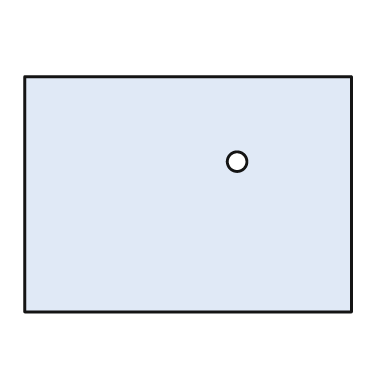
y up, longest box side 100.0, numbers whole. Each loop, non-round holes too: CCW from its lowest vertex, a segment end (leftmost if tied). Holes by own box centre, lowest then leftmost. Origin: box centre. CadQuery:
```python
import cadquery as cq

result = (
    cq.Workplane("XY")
    .moveTo(-50.0, -36.0)
    .lineTo(50.0, -36.0)
    .lineTo(50.0, 36.0)
    .lineTo(-50.0, 36.0)
    .close()
    .moveTo(15.0, 10.0)
    .circle(3.0)
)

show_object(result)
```